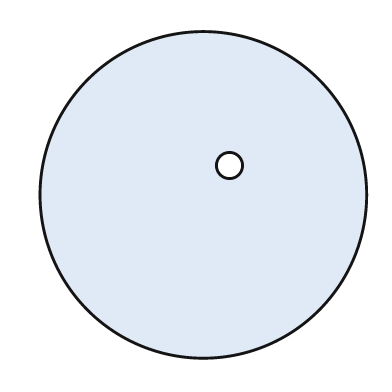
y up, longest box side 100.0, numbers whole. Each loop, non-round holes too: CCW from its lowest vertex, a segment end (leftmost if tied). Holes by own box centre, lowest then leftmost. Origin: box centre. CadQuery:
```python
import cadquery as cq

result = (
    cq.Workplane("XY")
    .moveTo(0.0, 0.0)
    .circle(50.0)
    .moveTo(8.0, 9.0)
    .circle(4.0)
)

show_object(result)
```